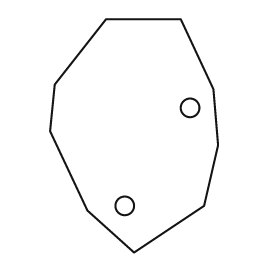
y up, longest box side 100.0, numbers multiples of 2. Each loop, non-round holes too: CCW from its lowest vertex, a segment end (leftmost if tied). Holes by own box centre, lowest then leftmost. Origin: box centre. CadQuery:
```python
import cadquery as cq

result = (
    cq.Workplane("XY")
    .moveTo(0.0, -50.0)
    .lineTo(30.0, -30.0)
    .lineTo(36.0, -4.0)
    .lineTo(34.0, 20.0)
    .lineTo(20.0, 50.0)
    .lineTo(-12.0, 50.0)
    .lineTo(-34.0, 22.0)
    .lineTo(-36.0, 2.0)
    .lineTo(-20.0, -32.0)
    .close()
    .moveTo(-4.0, -30.0)
    .circle(4.0)
    .moveTo(24.0, 12.0)
    .circle(4.0)
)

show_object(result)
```